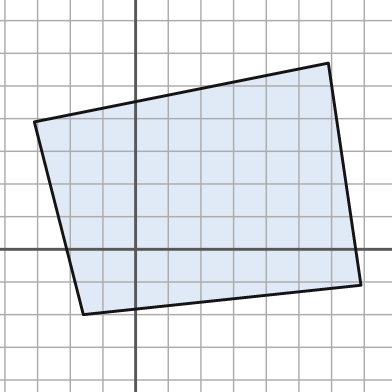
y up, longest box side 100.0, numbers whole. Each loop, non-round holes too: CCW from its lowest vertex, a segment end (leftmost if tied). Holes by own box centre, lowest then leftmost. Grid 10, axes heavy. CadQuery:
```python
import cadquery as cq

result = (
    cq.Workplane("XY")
    .moveTo(-16.0, -20.0)
    .lineTo(69.0, -11.0)
    .lineTo(59.0, 57.0)
    .lineTo(-31.0, 39.0)
    .close()
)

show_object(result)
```